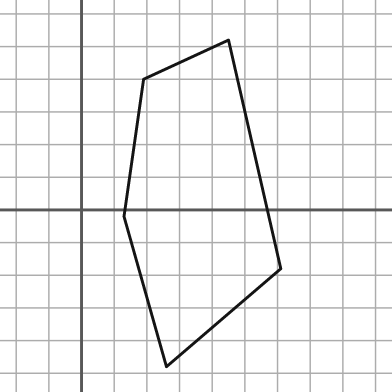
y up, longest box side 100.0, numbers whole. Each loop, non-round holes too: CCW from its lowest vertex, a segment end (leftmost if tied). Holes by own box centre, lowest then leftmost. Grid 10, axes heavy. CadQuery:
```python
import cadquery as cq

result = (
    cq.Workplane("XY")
    .moveTo(26.0, -48.0)
    .lineTo(61.0, -18.0)
    .lineTo(45.0, 52.0)
    .lineTo(19.0, 40.0)
    .lineTo(13.0, -2.0)
    .close()
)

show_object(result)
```